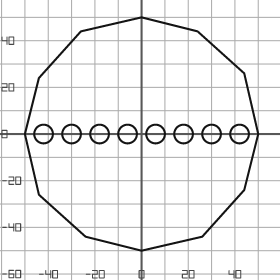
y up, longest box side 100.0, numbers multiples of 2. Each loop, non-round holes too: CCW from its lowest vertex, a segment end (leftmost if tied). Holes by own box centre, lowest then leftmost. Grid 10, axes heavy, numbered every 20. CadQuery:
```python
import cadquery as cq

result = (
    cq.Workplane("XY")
    .moveTo(0.0, -50.0)
    .lineTo(26.0, -44.0)
    .lineTo(44.0, -24.0)
    .lineTo(50.0, 0.0)
    .lineTo(44.0, 26.0)
    .lineTo(24.0, 44.0)
    .lineTo(0.0, 50.0)
    .lineTo(-26.0, 44.0)
    .lineTo(-44.0, 24.0)
    .lineTo(-50.0, 0.0)
    .lineTo(-44.0, -26.0)
    .lineTo(-24.0, -44.0)
    .close()
    .moveTo(-42.0, 0.0)
    .circle(4.0)
    .moveTo(-30.0, 0.0)
    .circle(4.0)
    .moveTo(-18.0, 0.0)
    .circle(4.0)
    .moveTo(-6.0, 0.0)
    .circle(4.0)
    .moveTo(6.0, 0.0)
    .circle(4.0)
    .moveTo(18.0, 0.0)
    .circle(4.0)
    .moveTo(30.0, 0.0)
    .circle(4.0)
    .moveTo(42.0, 0.0)
    .circle(4.0)
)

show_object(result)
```